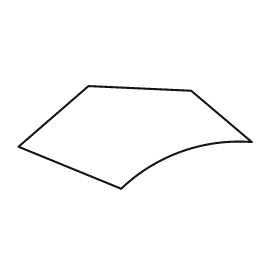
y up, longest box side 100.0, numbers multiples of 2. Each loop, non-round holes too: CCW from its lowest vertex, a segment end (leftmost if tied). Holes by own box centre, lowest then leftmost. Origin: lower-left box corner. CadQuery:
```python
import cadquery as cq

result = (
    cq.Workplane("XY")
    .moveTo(44.0, 0.0)
    .threePointArc((70.0, 16.0), (100.0, 20.0))
    .lineTo(74.0, 42.0)
    .lineTo(30.0, 44.0)
    .lineTo(0.0, 18.0)
    .close()
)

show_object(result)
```